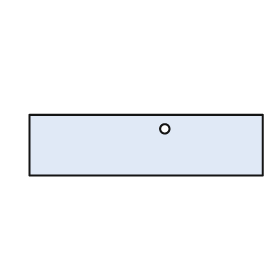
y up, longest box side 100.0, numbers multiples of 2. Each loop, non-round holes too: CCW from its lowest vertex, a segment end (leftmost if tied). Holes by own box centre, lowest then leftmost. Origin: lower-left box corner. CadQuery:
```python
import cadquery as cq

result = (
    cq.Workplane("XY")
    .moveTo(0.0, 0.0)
    .lineTo(100.0, 0.0)
    .lineTo(100.0, 26.0)
    .lineTo(0.0, 26.0)
    .close()
    .moveTo(58.0, 20.0)
    .circle(2.0)
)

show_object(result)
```